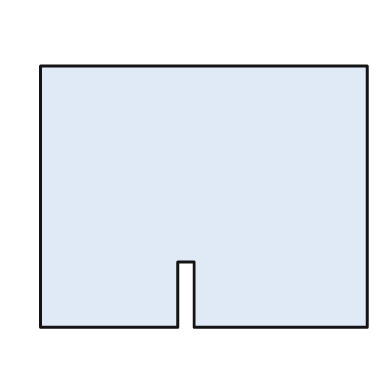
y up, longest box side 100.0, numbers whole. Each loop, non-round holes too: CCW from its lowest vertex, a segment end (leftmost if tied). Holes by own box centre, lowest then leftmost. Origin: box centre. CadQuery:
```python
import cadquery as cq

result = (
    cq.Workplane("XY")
    .moveTo(-50.0, -40.0)
    .lineTo(-8.0, -40.0)
    .lineTo(-8.0, -20.0)
    .lineTo(-3.0, -20.0)
    .lineTo(-3.0, -40.0)
    .lineTo(50.0, -40.0)
    .lineTo(50.0, 40.0)
    .lineTo(-50.0, 40.0)
    .close()
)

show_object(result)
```